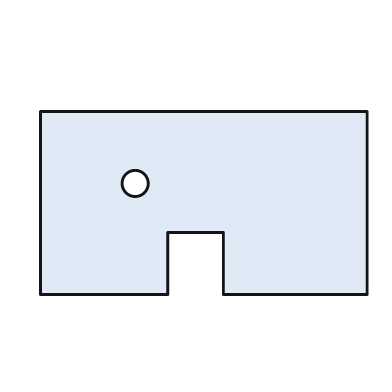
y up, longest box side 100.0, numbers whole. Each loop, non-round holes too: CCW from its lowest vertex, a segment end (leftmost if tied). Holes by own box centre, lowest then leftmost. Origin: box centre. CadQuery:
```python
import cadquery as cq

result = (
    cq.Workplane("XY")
    .moveTo(-50.0, -28.0)
    .lineTo(-11.0, -28.0)
    .lineTo(-11.0, -9.0)
    .lineTo(6.0, -9.0)
    .lineTo(6.0, -28.0)
    .lineTo(50.0, -28.0)
    .lineTo(50.0, 28.0)
    .lineTo(-50.0, 28.0)
    .close()
    .moveTo(-21.0, 6.0)
    .circle(4.0)
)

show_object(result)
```